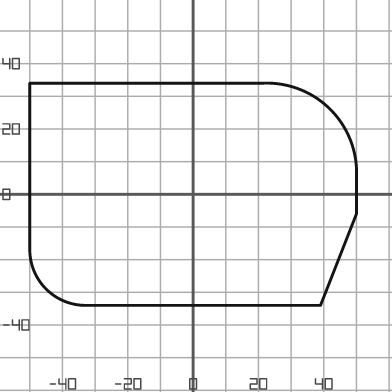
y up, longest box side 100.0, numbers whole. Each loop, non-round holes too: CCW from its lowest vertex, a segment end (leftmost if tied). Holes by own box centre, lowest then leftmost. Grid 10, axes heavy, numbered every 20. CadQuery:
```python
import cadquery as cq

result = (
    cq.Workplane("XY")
    .moveTo(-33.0, -34.0)
    .lineTo(39.0, -34.0)
    .lineTo(50.0, -6.0)
    .lineTo(50.0, 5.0)
    .threePointArc((42.0, 26.0), (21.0, 34.0))
    .lineTo(-50.0, 34.0)
    .lineTo(-50.0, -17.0)
    .threePointArc((-45.0, -29.0), (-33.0, -34.0))
    .close()
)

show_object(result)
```